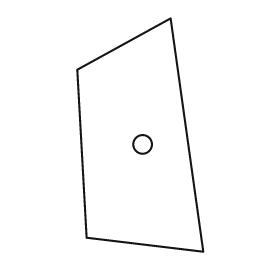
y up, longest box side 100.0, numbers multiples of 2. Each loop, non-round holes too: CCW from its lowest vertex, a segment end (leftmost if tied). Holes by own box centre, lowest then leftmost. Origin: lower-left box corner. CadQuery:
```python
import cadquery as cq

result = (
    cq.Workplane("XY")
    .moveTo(54.0, 0.0)
    .lineTo(40.0, 100.0)
    .lineTo(0.0, 78.0)
    .lineTo(4.0, 6.0)
    .close()
    .moveTo(28.0, 46.0)
    .circle(4.0)
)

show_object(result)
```